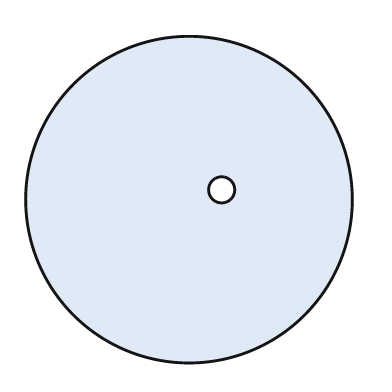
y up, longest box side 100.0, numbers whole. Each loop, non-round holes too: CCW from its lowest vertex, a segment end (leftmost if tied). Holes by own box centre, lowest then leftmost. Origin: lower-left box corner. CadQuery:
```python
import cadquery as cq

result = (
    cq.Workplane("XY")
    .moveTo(50.0, 50.0)
    .circle(50.0)
    .moveTo(60.0, 53.0)
    .circle(4.0)
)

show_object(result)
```